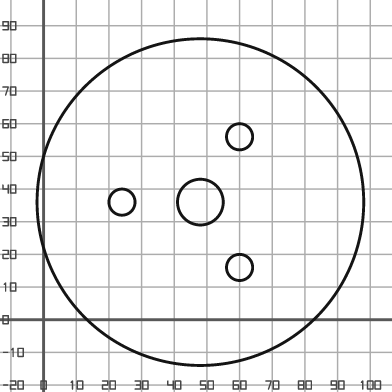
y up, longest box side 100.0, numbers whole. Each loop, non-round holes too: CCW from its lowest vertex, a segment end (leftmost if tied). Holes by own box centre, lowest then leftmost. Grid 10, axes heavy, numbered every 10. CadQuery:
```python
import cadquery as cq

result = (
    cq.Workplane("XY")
    .moveTo(48.0, 36.0)
    .circle(50.0)
    .moveTo(60.0, 16.0)
    .circle(4.0)
    .moveTo(24.0, 36.0)
    .circle(4.0)
    .moveTo(48.0, 36.0)
    .circle(7.0)
    .moveTo(60.0, 56.0)
    .circle(4.0)
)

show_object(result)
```